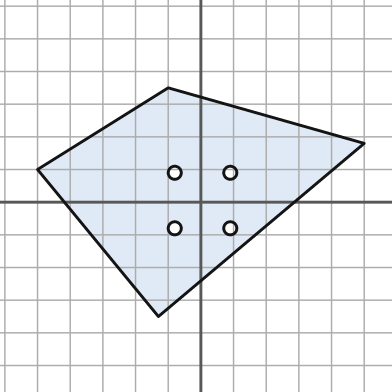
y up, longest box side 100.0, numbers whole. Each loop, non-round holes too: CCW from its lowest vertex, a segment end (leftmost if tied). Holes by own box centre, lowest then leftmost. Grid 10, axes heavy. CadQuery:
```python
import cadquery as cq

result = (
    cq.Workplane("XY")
    .moveTo(-13.0, -35.0)
    .lineTo(50.0, 18.0)
    .lineTo(-10.0, 35.0)
    .lineTo(-50.0, 10.0)
    .close()
    .moveTo(-8.0, -8.0)
    .circle(2.0)
    .moveTo(9.0, -8.0)
    .circle(2.0)
    .moveTo(-8.0, 9.0)
    .circle(2.0)
    .moveTo(9.0, 9.0)
    .circle(2.0)
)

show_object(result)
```